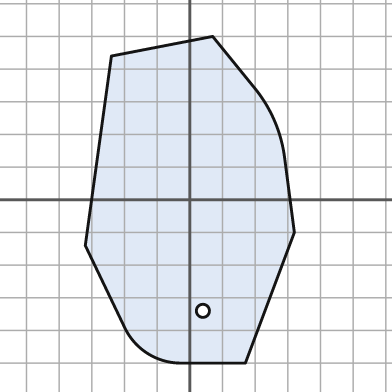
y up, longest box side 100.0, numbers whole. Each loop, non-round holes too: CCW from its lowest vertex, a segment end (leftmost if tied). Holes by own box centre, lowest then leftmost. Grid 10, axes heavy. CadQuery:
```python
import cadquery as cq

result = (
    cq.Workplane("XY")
    .moveTo(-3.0, -50.0)
    .lineTo(17.0, -50.0)
    .lineTo(32.0, -10.0)
    .lineTo(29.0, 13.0)
    .threePointArc((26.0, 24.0), (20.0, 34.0))
    .lineTo(7.0, 50.0)
    .lineTo(-24.0, 44.0)
    .lineTo(-32.0, -14.0)
    .lineTo(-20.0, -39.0)
    .threePointArc((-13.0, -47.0), (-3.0, -50.0))
    .close()
    .moveTo(4.0, -34.0)
    .circle(2.0)
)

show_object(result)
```